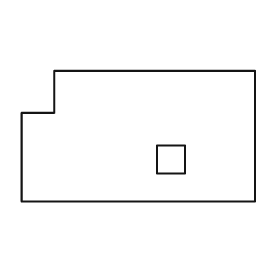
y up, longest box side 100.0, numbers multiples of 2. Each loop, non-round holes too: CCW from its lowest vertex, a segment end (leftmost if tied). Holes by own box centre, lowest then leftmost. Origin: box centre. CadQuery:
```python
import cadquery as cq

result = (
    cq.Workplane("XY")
    .moveTo(-50.0, -28.0)
    .lineTo(50.0, -28.0)
    .lineTo(50.0, 28.0)
    .lineTo(-36.0, 28.0)
    .lineTo(-36.0, 10.0)
    .lineTo(-50.0, 10.0)
    .close()
    .moveTo(8.0, -16.0)
    .lineTo(20.0, -16.0)
    .lineTo(20.0, -4.0)
    .lineTo(8.0, -4.0)
    .close()
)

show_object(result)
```